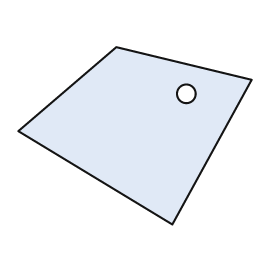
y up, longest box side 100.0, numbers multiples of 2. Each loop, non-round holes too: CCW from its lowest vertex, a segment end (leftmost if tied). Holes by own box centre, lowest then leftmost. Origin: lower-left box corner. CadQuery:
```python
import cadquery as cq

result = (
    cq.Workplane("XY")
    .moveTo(66.0, 0.0)
    .lineTo(100.0, 62.0)
    .lineTo(42.0, 76.0)
    .lineTo(0.0, 40.0)
    .close()
    .moveTo(72.0, 56.0)
    .circle(4.0)
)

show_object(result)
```